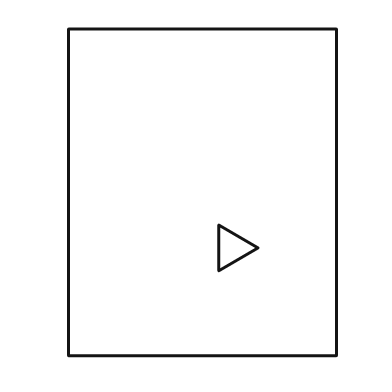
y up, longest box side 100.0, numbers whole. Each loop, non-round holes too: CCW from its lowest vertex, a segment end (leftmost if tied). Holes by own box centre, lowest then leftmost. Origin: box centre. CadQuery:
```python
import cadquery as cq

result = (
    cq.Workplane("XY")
    .moveTo(-41.0, -50.0)
    .lineTo(41.0, -50.0)
    .lineTo(41.0, 50.0)
    .lineTo(-41.0, 50.0)
    .close()
    .moveTo(5.0, -24.0)
    .lineTo(17.0, -17.0)
    .lineTo(5.0, -10.0)
    .close()
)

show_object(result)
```